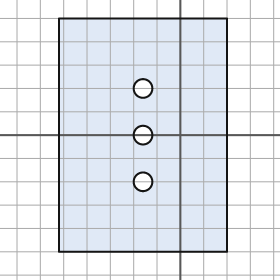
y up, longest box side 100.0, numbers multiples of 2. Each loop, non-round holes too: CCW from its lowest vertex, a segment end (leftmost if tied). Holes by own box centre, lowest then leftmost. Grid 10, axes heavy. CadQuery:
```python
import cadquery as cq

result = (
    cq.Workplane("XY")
    .moveTo(-52.0, -50.0)
    .lineTo(20.0, -50.0)
    .lineTo(20.0, 50.0)
    .lineTo(-52.0, 50.0)
    .close()
    .moveTo(-16.0, -20.0)
    .circle(4.0)
    .moveTo(-16.0, 0.0)
    .circle(4.0)
    .moveTo(-16.0, 20.0)
    .circle(4.0)
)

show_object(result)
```